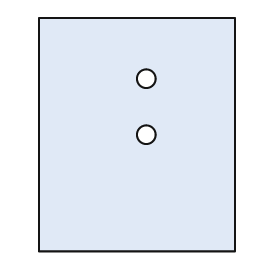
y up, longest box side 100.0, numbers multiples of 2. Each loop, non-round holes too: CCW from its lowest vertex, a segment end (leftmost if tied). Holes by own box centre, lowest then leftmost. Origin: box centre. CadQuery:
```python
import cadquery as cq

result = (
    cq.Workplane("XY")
    .moveTo(-42.0, -50.0)
    .lineTo(42.0, -50.0)
    .lineTo(42.0, 50.0)
    .lineTo(-42.0, 50.0)
    .close()
    .moveTo(4.0, 0.0)
    .circle(4.0)
    .moveTo(4.0, 24.0)
    .circle(4.0)
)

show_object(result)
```